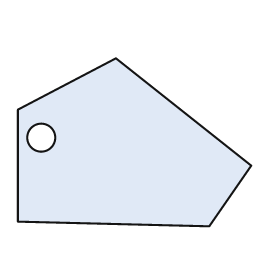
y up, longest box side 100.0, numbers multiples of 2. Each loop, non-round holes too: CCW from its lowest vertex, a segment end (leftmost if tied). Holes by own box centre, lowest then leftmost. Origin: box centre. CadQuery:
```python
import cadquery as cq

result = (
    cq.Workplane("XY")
    .moveTo(32.0, -36.0)
    .lineTo(50.0, -10.0)
    .lineTo(-8.0, 36.0)
    .lineTo(-50.0, 14.0)
    .lineTo(-50.0, -34.0)
    .close()
    .moveTo(-40.0, 2.0)
    .circle(6.0)
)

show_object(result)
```